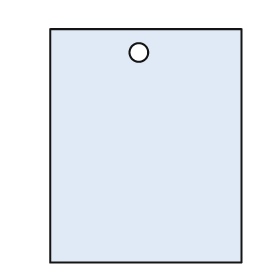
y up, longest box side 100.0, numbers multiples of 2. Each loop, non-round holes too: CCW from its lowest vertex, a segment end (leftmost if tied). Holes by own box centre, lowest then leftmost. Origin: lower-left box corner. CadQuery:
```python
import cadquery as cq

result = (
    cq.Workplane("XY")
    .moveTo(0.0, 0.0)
    .lineTo(82.0, 0.0)
    .lineTo(82.0, 100.0)
    .lineTo(0.0, 100.0)
    .close()
    .moveTo(38.0, 90.0)
    .circle(4.0)
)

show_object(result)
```